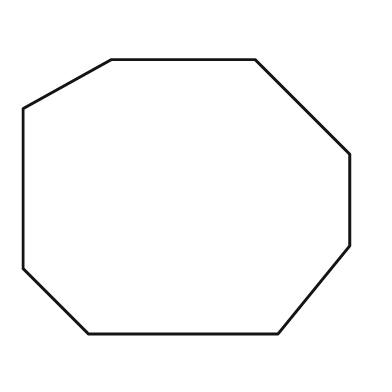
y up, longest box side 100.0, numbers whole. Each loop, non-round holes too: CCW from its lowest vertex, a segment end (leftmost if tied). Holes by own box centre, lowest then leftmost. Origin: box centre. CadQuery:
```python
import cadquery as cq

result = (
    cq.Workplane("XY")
    .moveTo(-30.0, -42.0)
    .lineTo(28.0, -42.0)
    .lineTo(50.0, -15.0)
    .lineTo(50.0, 13.0)
    .lineTo(21.0, 42.0)
    .lineTo(-23.0, 42.0)
    .lineTo(-50.0, 27.0)
    .lineTo(-50.0, -22.0)
    .close()
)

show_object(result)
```